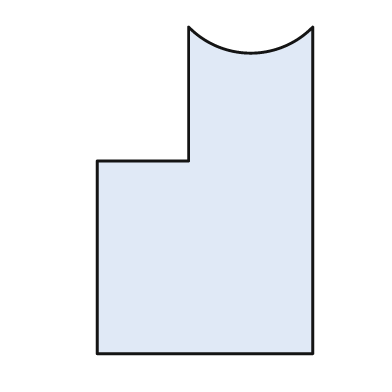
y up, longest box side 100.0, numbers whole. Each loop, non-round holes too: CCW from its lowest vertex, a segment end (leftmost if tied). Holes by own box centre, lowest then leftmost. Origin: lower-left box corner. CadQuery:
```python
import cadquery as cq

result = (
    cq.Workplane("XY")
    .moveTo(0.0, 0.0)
    .lineTo(66.0, 0.0)
    .lineTo(66.0, 100.0)
    .threePointArc((47.0, 92.0), (28.0, 100.0))
    .lineTo(28.0, 59.0)
    .lineTo(0.0, 59.0)
    .close()
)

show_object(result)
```